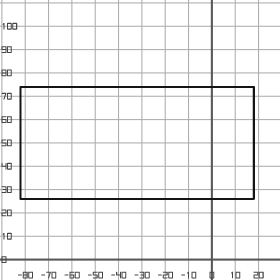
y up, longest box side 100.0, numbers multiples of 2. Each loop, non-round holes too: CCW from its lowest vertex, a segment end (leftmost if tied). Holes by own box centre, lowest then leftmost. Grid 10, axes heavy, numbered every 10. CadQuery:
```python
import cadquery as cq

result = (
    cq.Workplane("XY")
    .moveTo(-82.0, 26.0)
    .lineTo(18.0, 26.0)
    .lineTo(18.0, 74.0)
    .lineTo(-82.0, 74.0)
    .close()
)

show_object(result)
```